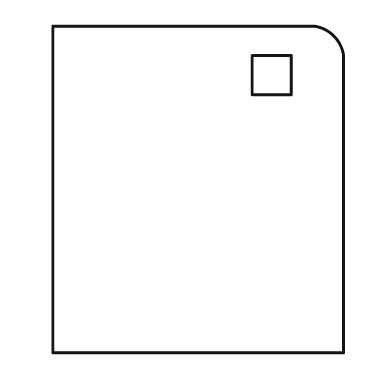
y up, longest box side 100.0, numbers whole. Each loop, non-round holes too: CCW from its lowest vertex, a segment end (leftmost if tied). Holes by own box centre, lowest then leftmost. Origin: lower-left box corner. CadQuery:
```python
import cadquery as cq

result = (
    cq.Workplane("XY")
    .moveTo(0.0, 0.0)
    .lineTo(89.0, 0.0)
    .lineTo(89.0, 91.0)
    .threePointArc((86.0, 97.0), (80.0, 100.0))
    .lineTo(0.0, 100.0)
    .close()
    .moveTo(61.0, 79.0)
    .lineTo(73.0, 79.0)
    .lineTo(73.0, 91.0)
    .lineTo(61.0, 91.0)
    .close()
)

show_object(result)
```